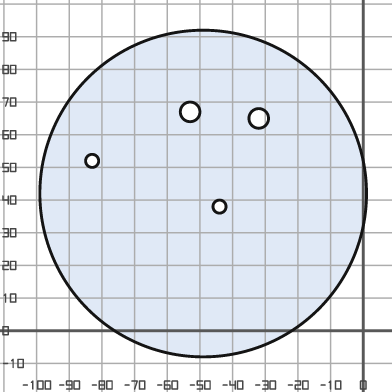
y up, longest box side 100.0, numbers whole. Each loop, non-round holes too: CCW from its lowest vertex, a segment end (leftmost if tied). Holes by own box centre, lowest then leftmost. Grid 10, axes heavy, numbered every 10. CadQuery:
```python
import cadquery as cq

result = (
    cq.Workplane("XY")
    .moveTo(-49.0, 42.0)
    .circle(50.0)
    .moveTo(-44.0, 38.0)
    .circle(2.0)
    .moveTo(-83.0, 52.0)
    .circle(2.0)
    .moveTo(-32.0, 65.0)
    .circle(3.0)
    .moveTo(-53.0, 67.0)
    .circle(3.0)
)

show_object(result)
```